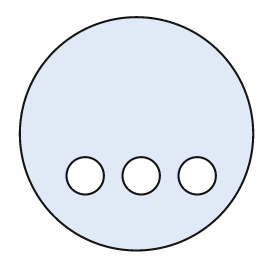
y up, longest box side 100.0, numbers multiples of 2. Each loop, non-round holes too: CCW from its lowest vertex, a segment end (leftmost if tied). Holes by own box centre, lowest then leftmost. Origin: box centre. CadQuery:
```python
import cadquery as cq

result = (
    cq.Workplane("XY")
    .moveTo(0.0, 0.0)
    .circle(50.0)
    .moveTo(-22.0, -18.0)
    .circle(8.0)
    .moveTo(2.0, -18.0)
    .circle(8.0)
    .moveTo(26.0, -18.0)
    .circle(8.0)
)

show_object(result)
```